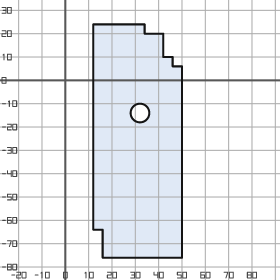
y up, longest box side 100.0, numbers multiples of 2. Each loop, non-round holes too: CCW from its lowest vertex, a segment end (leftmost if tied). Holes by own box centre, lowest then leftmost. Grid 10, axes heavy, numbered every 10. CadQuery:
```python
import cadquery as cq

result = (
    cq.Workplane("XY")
    .moveTo(16.0, -76.0)
    .lineTo(50.0, -76.0)
    .lineTo(50.0, 6.0)
    .lineTo(46.0, 6.0)
    .lineTo(46.0, 10.0)
    .lineTo(42.0, 10.0)
    .lineTo(42.0, 20.0)
    .lineTo(34.0, 20.0)
    .lineTo(34.0, 24.0)
    .lineTo(12.0, 24.0)
    .lineTo(12.0, -64.0)
    .lineTo(16.0, -64.0)
    .close()
    .moveTo(32.0, -14.0)
    .circle(4.0)
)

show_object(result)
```